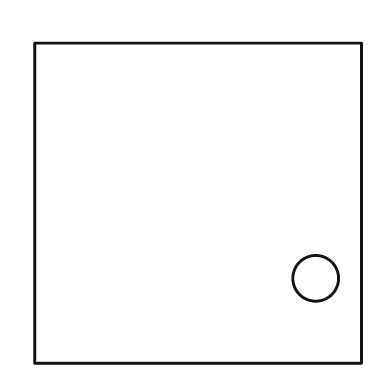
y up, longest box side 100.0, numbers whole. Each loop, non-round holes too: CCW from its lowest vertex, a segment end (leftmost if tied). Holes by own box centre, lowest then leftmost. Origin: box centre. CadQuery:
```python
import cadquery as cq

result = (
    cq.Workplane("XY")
    .moveTo(-50.0, -49.0)
    .lineTo(50.0, -49.0)
    .lineTo(50.0, 49.0)
    .lineTo(-50.0, 49.0)
    .close()
    .moveTo(36.0, -23.0)
    .circle(7.0)
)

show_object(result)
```